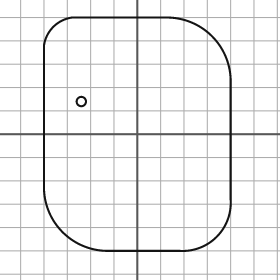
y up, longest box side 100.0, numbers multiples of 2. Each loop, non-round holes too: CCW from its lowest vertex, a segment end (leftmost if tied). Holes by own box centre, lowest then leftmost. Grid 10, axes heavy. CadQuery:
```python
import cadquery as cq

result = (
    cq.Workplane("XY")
    .moveTo(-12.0, -50.0)
    .lineTo(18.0, -50.0)
    .threePointArc((34.0, -44.0), (40.0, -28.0))
    .lineTo(40.0, 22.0)
    .threePointArc((32.0, 42.0), (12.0, 50.0))
    .lineTo(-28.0, 50.0)
    .threePointArc((-36.0, 46.0), (-40.0, 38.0))
    .lineTo(-40.0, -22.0)
    .threePointArc((-32.0, -42.0), (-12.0, -50.0))
    .close()
    .moveTo(-24.0, 14.0)
    .circle(2.0)
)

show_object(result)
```